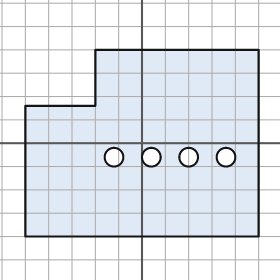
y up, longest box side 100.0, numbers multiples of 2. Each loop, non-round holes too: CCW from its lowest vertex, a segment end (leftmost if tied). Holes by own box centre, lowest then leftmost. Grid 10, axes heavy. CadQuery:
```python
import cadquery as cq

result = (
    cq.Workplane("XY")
    .moveTo(-50.0, -40.0)
    .lineTo(50.0, -40.0)
    .lineTo(50.0, 40.0)
    .lineTo(-20.0, 40.0)
    .lineTo(-20.0, 16.0)
    .lineTo(-50.0, 16.0)
    .close()
    .moveTo(-12.0, -6.0)
    .circle(4.0)
    .moveTo(4.0, -6.0)
    .circle(4.0)
    .moveTo(20.0, -6.0)
    .circle(4.0)
    .moveTo(36.0, -6.0)
    .circle(4.0)
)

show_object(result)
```